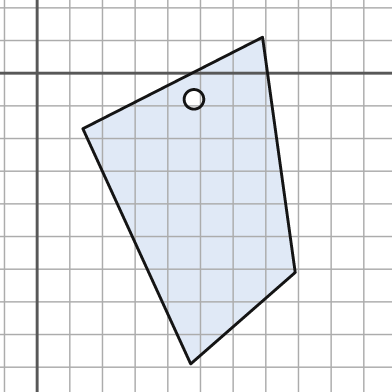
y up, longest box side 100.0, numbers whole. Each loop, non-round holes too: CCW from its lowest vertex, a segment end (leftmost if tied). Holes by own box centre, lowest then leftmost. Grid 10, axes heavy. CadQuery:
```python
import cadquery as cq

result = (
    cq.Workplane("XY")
    .moveTo(47.0, -89.0)
    .lineTo(79.0, -61.0)
    .lineTo(69.0, 11.0)
    .lineTo(14.0, -17.0)
    .close()
    .moveTo(48.0, -8.0)
    .circle(3.0)
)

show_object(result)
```